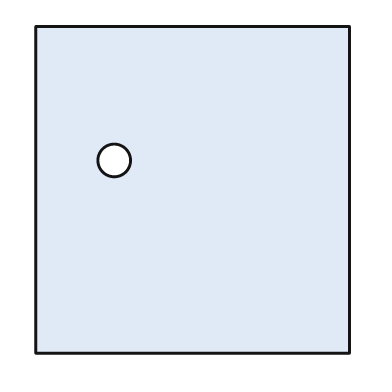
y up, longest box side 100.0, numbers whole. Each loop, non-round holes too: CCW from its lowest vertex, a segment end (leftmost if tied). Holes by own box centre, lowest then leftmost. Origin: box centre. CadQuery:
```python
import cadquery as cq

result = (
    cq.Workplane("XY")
    .moveTo(-48.0, -50.0)
    .lineTo(48.0, -50.0)
    .lineTo(48.0, 50.0)
    .lineTo(-48.0, 50.0)
    .close()
    .moveTo(-24.0, 9.0)
    .circle(5.0)
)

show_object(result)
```